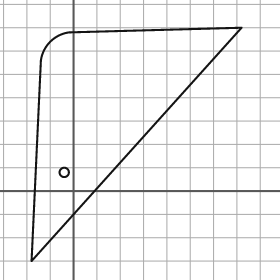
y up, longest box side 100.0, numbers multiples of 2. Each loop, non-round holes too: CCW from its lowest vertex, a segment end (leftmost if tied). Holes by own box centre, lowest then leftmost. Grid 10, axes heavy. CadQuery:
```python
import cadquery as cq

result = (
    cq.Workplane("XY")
    .moveTo(-18.0, -30.0)
    .lineTo(72.0, 70.0)
    .lineTo(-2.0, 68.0)
    .threePointArc((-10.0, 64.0), (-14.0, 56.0))
    .close()
    .moveTo(-4.0, 8.0)
    .circle(2.0)
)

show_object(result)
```